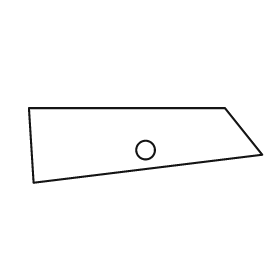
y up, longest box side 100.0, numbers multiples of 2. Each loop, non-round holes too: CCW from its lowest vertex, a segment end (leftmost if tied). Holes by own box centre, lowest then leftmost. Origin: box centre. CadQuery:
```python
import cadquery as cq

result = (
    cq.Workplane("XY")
    .moveTo(-48.0, -16.0)
    .lineTo(50.0, -4.0)
    .lineTo(34.0, 16.0)
    .lineTo(-50.0, 16.0)
    .close()
    .moveTo(0.0, -2.0)
    .circle(4.0)
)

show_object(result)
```